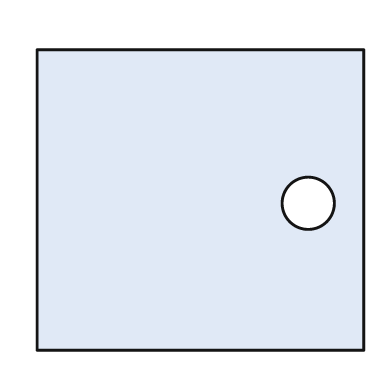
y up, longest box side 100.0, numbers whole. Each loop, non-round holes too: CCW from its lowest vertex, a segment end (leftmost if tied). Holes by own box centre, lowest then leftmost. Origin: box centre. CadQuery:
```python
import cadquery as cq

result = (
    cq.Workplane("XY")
    .moveTo(-50.0, -46.0)
    .lineTo(50.0, -46.0)
    .lineTo(50.0, 46.0)
    .lineTo(-50.0, 46.0)
    .close()
    .moveTo(33.0, -1.0)
    .circle(8.0)
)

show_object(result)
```